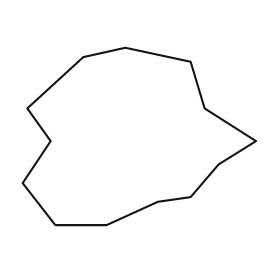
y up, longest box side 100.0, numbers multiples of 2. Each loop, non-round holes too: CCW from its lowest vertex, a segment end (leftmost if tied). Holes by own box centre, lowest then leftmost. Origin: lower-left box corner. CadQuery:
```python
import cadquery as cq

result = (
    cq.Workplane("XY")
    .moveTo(14.0, 0.0)
    .lineTo(36.0, 0.0)
    .lineTo(58.0, 10.0)
    .lineTo(72.0, 12.0)
    .lineTo(84.0, 26.0)
    .lineTo(100.0, 36.0)
    .lineTo(78.0, 50.0)
    .lineTo(72.0, 70.0)
    .lineTo(44.0, 76.0)
    .lineTo(26.0, 72.0)
    .lineTo(2.0, 50.0)
    .lineTo(12.0, 36.0)
    .lineTo(0.0, 18.0)
    .close()
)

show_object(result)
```